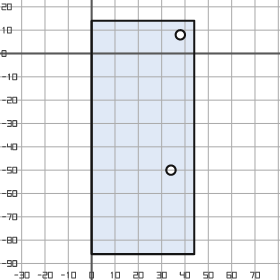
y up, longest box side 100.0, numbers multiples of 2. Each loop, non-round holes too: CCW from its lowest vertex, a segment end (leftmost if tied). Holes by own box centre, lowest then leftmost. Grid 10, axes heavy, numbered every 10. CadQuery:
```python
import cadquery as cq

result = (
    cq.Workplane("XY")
    .moveTo(0.0, -86.0)
    .lineTo(44.0, -86.0)
    .lineTo(44.0, 14.0)
    .lineTo(0.0, 14.0)
    .close()
    .moveTo(34.0, -50.0)
    .circle(2.0)
    .moveTo(38.0, 8.0)
    .circle(2.0)
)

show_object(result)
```